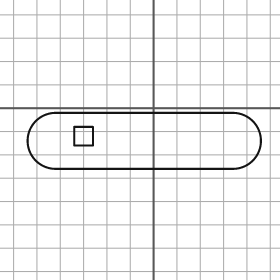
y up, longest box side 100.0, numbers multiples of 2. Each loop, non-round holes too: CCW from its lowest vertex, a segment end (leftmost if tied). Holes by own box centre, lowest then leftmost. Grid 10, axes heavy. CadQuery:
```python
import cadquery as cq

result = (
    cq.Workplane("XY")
    .moveTo(-42.0, -26.0)
    .lineTo(34.0, -26.0)
    .threePointArc((46.0, -14.0), (34.0, -2.0))
    .lineTo(-42.0, -2.0)
    .threePointArc((-54.0, -14.0), (-42.0, -26.0))
    .close()
    .moveTo(-34.0, -16.0)
    .lineTo(-26.0, -16.0)
    .lineTo(-26.0, -8.0)
    .lineTo(-34.0, -8.0)
    .close()
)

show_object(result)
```